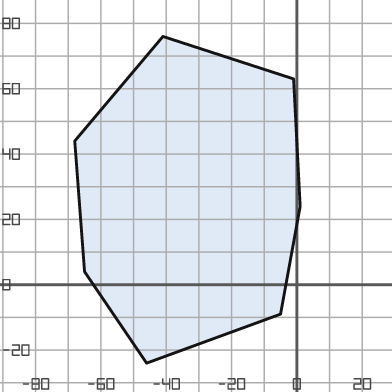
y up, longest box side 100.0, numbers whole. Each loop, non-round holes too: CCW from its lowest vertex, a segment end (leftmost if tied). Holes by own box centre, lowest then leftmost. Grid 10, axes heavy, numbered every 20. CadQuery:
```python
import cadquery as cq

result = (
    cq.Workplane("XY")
    .moveTo(-46.0, -24.0)
    .lineTo(-5.0, -9.0)
    .lineTo(1.0, 24.0)
    .lineTo(-1.0, 63.0)
    .lineTo(-41.0, 76.0)
    .lineTo(-68.0, 44.0)
    .lineTo(-65.0, 4.0)
    .close()
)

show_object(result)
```